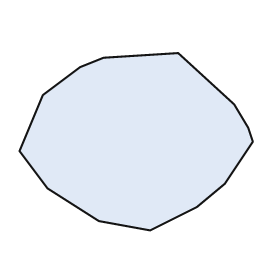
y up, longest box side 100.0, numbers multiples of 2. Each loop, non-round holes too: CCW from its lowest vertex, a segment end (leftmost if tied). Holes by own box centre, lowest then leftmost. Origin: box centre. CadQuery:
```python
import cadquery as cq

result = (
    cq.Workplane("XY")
    .moveTo(6.0, -38.0)
    .lineTo(26.0, -28.0)
    .lineTo(38.0, -18.0)
    .lineTo(50.0, 0.0)
    .lineTo(48.0, 6.0)
    .lineTo(42.0, 16.0)
    .lineTo(18.0, 38.0)
    .lineTo(-14.0, 36.0)
    .lineTo(-24.0, 32.0)
    .lineTo(-40.0, 20.0)
    .lineTo(-50.0, -4.0)
    .lineTo(-38.0, -20.0)
    .lineTo(-16.0, -34.0)
    .close()
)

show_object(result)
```